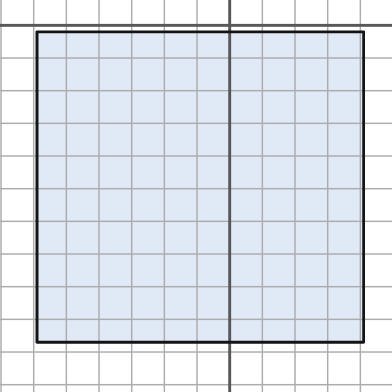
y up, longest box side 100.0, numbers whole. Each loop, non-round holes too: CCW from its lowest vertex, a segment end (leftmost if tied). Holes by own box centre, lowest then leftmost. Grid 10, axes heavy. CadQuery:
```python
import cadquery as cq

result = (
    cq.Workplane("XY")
    .moveTo(-59.0, -97.0)
    .lineTo(41.0, -97.0)
    .lineTo(41.0, -2.0)
    .lineTo(-59.0, -2.0)
    .close()
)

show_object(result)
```